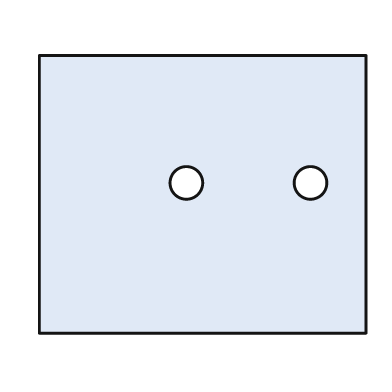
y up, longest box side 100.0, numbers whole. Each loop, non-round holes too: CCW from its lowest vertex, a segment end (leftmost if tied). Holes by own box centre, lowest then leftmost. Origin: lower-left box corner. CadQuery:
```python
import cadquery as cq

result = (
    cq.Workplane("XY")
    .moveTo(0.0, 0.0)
    .lineTo(100.0, 0.0)
    .lineTo(100.0, 85.0)
    .lineTo(0.0, 85.0)
    .close()
    .moveTo(45.0, 46.0)
    .circle(5.0)
    .moveTo(83.0, 46.0)
    .circle(5.0)
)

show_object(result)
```